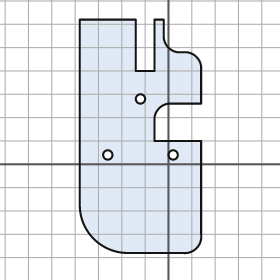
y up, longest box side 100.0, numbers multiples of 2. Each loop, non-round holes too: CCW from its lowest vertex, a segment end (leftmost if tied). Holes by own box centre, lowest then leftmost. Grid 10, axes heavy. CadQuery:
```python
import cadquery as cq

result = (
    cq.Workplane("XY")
    .moveTo(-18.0, -38.0)
    .lineTo(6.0, -38.0)
    .threePointArc((12.0, -36.0), (14.0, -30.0))
    .lineTo(14.0, 10.0)
    .lineTo(-6.0, 10.0)
    .lineTo(-6.0, 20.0)
    .threePointArc((-4.0, 24.0), (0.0, 26.0))
    .lineTo(14.0, 26.0)
    .lineTo(14.0, 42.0)
    .threePointArc((12.0, 46.0), (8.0, 48.0))
    .lineTo(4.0, 48.0)
    .threePointArc((0.0, 50.0), (-2.0, 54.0))
    .lineTo(-2.0, 62.0)
    .lineTo(-6.0, 62.0)
    .lineTo(-6.0, 40.0)
    .lineTo(-14.0, 40.0)
    .lineTo(-14.0, 62.0)
    .lineTo(-38.0, 62.0)
    .lineTo(-38.0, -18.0)
    .threePointArc((-32.0, -32.0), (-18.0, -38.0))
    .close()
    .moveTo(-26.0, 4.0)
    .circle(2.0)
    .moveTo(2.0, 4.0)
    .circle(2.0)
    .moveTo(-12.0, 28.0)
    .circle(2.0)
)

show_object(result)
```